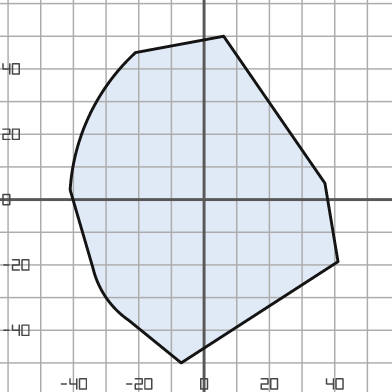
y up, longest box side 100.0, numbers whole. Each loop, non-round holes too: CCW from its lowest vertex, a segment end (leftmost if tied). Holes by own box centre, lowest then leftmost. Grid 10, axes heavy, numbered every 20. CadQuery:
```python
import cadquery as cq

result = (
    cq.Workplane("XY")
    .moveTo(-7.0, -50.0)
    .lineTo(41.0, -19.0)
    .lineTo(37.0, 5.0)
    .lineTo(6.0, 50.0)
    .lineTo(-21.0, 45.0)
    .threePointArc((-35.0, 26.0), (-41.0, 3.0))
    .lineTo(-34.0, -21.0)
    .threePointArc((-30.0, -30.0), (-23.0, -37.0))
    .close()
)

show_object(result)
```